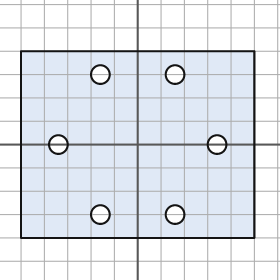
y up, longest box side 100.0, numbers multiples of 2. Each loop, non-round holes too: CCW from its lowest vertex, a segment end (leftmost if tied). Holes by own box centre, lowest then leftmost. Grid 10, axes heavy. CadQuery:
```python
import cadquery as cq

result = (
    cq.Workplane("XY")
    .moveTo(-50.0, -40.0)
    .lineTo(50.0, -40.0)
    .lineTo(50.0, 40.0)
    .lineTo(-50.0, 40.0)
    .close()
    .moveTo(-16.0, -30.0)
    .circle(4.0)
    .moveTo(16.0, -30.0)
    .circle(4.0)
    .moveTo(-34.0, 0.0)
    .circle(4.0)
    .moveTo(34.0, 0.0)
    .circle(4.0)
    .moveTo(-16.0, 30.0)
    .circle(4.0)
    .moveTo(16.0, 30.0)
    .circle(4.0)
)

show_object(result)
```